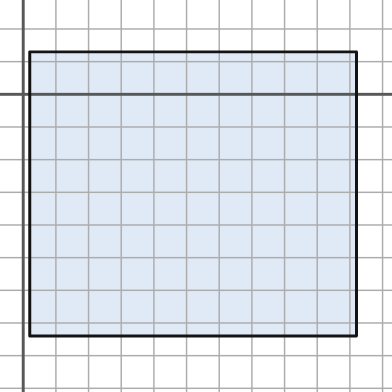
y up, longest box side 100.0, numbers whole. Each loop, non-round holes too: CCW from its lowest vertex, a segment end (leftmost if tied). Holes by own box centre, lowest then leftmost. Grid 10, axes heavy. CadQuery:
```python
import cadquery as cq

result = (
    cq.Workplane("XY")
    .moveTo(2.0, -74.0)
    .lineTo(102.0, -74.0)
    .lineTo(102.0, 13.0)
    .lineTo(2.0, 13.0)
    .close()
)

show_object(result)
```